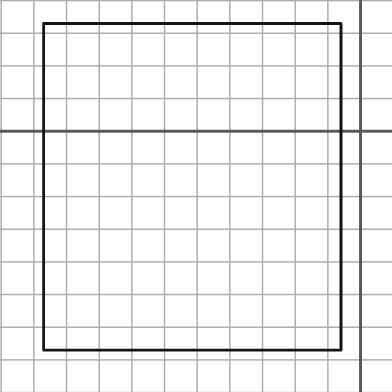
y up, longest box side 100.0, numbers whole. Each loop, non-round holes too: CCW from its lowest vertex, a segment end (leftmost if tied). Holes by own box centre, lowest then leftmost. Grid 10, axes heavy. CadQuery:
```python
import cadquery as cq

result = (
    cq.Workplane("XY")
    .moveTo(-97.0, -67.0)
    .lineTo(-6.0, -67.0)
    .lineTo(-6.0, 33.0)
    .lineTo(-97.0, 33.0)
    .close()
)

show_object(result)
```